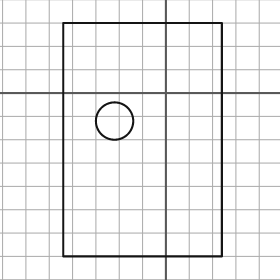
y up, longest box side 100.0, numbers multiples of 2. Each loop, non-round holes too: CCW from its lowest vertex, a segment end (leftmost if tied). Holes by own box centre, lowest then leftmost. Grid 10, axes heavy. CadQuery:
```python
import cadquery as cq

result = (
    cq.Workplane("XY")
    .moveTo(-44.0, -70.0)
    .lineTo(24.0, -70.0)
    .lineTo(24.0, 30.0)
    .lineTo(-44.0, 30.0)
    .close()
    .moveTo(-22.0, -12.0)
    .circle(8.0)
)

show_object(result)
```